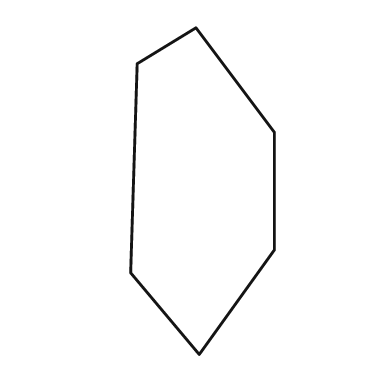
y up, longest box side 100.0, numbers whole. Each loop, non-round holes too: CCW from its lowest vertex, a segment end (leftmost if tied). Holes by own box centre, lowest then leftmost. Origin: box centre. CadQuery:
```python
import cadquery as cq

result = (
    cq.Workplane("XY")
    .moveTo(-1.0, -50.0)
    .lineTo(22.0, -18.0)
    .lineTo(22.0, 18.0)
    .lineTo(-2.0, 50.0)
    .lineTo(-20.0, 39.0)
    .lineTo(-22.0, -25.0)
    .close()
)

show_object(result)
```